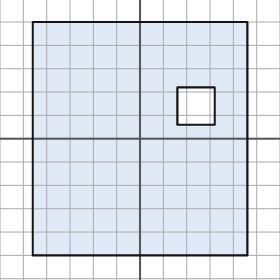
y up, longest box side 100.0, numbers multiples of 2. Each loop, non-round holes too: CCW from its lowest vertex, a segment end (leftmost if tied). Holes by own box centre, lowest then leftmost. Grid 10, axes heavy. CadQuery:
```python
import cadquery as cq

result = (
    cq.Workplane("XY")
    .moveTo(-46.0, -50.0)
    .lineTo(46.0, -50.0)
    .lineTo(46.0, 50.0)
    .lineTo(-46.0, 50.0)
    .close()
    .moveTo(16.0, 6.0)
    .lineTo(32.0, 6.0)
    .lineTo(32.0, 22.0)
    .lineTo(16.0, 22.0)
    .close()
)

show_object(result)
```